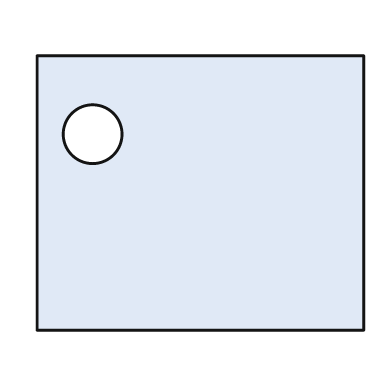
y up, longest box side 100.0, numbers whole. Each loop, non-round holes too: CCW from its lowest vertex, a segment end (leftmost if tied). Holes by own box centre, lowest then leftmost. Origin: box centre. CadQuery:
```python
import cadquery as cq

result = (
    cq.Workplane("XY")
    .moveTo(-50.0, -42.0)
    .lineTo(50.0, -42.0)
    .lineTo(50.0, 42.0)
    .lineTo(-50.0, 42.0)
    .close()
    .moveTo(-33.0, 18.0)
    .circle(9.0)
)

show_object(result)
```